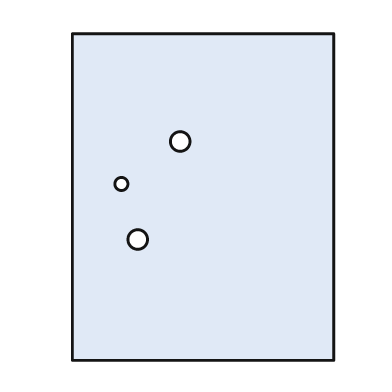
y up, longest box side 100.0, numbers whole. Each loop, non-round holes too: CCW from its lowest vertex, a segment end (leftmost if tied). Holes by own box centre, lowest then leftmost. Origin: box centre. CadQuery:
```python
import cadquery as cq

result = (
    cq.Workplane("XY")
    .moveTo(-40.0, -50.0)
    .lineTo(40.0, -50.0)
    .lineTo(40.0, 50.0)
    .lineTo(-40.0, 50.0)
    .close()
    .moveTo(-20.0, -13.0)
    .circle(3.0)
    .moveTo(-25.0, 4.0)
    .circle(2.0)
    .moveTo(-7.0, 17.0)
    .circle(3.0)
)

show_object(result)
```